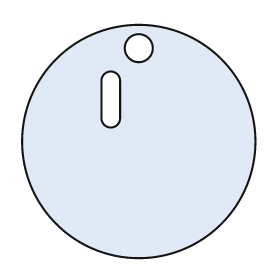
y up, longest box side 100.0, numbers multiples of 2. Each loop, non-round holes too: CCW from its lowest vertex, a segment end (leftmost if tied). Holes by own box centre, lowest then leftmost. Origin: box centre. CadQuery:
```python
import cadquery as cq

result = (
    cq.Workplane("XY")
    .moveTo(0.0, 0.0)
    .circle(50.0)
    .moveTo(-16.0, 10.0)
    .threePointArc((-12.0, 6.0), (-8.0, 10.0))
    .lineTo(-8.0, 26.0)
    .threePointArc((-12.0, 30.0), (-16.0, 26.0))
    .close()
    .moveTo(0.0, 40.0)
    .circle(6.0)
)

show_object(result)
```